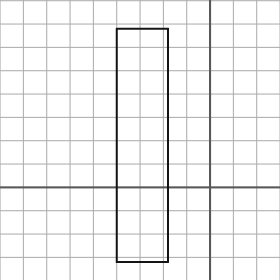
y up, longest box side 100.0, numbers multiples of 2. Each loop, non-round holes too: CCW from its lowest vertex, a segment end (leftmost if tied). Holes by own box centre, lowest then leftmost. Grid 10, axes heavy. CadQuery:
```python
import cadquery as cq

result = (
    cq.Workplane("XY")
    .moveTo(-40.0, -32.0)
    .lineTo(-18.0, -32.0)
    .lineTo(-18.0, 68.0)
    .lineTo(-40.0, 68.0)
    .close()
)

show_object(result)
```